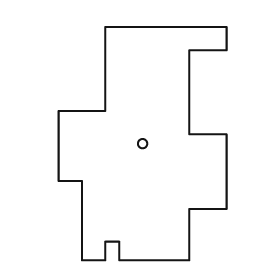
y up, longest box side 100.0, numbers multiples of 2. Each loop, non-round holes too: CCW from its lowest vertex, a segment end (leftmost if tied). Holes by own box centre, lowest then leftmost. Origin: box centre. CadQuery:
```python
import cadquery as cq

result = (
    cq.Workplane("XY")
    .moveTo(-26.0, -50.0)
    .lineTo(-16.0, -50.0)
    .lineTo(-16.0, -42.0)
    .lineTo(-10.0, -42.0)
    .lineTo(-10.0, -50.0)
    .lineTo(20.0, -50.0)
    .lineTo(20.0, -28.0)
    .lineTo(36.0, -28.0)
    .lineTo(36.0, 4.0)
    .lineTo(20.0, 4.0)
    .lineTo(20.0, 40.0)
    .lineTo(36.0, 40.0)
    .lineTo(36.0, 50.0)
    .lineTo(-16.0, 50.0)
    .lineTo(-16.0, 14.0)
    .lineTo(-36.0, 14.0)
    .lineTo(-36.0, -16.0)
    .lineTo(-26.0, -16.0)
    .close()
    .moveTo(0.0, 0.0)
    .circle(2.0)
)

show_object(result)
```